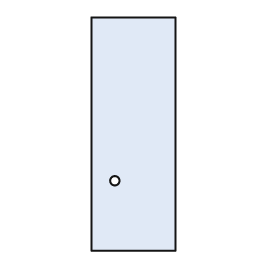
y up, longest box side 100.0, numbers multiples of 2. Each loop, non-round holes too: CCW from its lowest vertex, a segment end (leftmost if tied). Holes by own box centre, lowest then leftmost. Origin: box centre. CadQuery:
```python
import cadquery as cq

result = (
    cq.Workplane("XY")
    .moveTo(-18.0, -50.0)
    .lineTo(18.0, -50.0)
    .lineTo(18.0, 50.0)
    .lineTo(-18.0, 50.0)
    .close()
    .moveTo(-8.0, -20.0)
    .circle(2.0)
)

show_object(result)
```